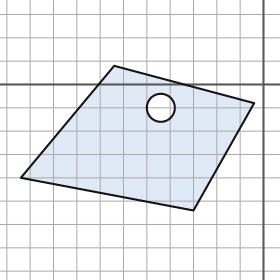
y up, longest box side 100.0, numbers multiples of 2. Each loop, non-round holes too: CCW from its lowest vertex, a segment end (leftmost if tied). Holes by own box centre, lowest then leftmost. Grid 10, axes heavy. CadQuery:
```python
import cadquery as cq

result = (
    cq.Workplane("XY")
    .moveTo(-30.0, -54.0)
    .lineTo(-4.0, -8.0)
    .lineTo(-64.0, 8.0)
    .lineTo(-104.0, -40.0)
    .close()
    .moveTo(-44.0, -10.0)
    .circle(6.0)
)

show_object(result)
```